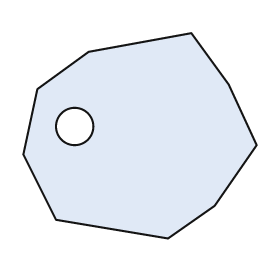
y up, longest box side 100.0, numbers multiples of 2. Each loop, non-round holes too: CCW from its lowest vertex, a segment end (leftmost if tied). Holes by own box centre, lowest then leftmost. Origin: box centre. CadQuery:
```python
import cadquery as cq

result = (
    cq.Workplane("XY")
    .moveTo(12.0, -44.0)
    .lineTo(32.0, -30.0)
    .lineTo(50.0, -4.0)
    .lineTo(38.0, 22.0)
    .lineTo(22.0, 44.0)
    .lineTo(-22.0, 36.0)
    .lineTo(-44.0, 20.0)
    .lineTo(-50.0, -8.0)
    .lineTo(-36.0, -36.0)
    .close()
    .moveTo(-28.0, 4.0)
    .circle(8.0)
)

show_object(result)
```